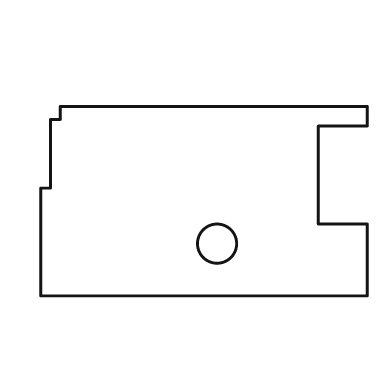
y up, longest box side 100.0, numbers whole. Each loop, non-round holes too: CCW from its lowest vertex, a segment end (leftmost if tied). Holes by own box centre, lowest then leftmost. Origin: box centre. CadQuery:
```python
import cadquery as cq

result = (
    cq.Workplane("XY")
    .moveTo(-50.0, -29.0)
    .lineTo(50.0, -29.0)
    .lineTo(50.0, -7.0)
    .lineTo(35.0, -7.0)
    .lineTo(35.0, 23.0)
    .lineTo(50.0, 23.0)
    .lineTo(50.0, 29.0)
    .lineTo(-44.0, 29.0)
    .lineTo(-44.0, 25.0)
    .lineTo(-47.0, 25.0)
    .lineTo(-47.0, 4.0)
    .lineTo(-50.0, 4.0)
    .close()
    .moveTo(4.0, -13.0)
    .circle(6.0)
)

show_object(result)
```